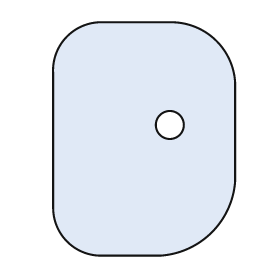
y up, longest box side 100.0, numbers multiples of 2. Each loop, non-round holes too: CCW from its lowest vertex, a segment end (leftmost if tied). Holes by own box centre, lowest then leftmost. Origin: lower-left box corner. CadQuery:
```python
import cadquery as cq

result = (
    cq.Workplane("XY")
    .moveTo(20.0, 0.0)
    .lineTo(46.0, 0.0)
    .threePointArc((68.0, 10.0), (78.0, 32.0))
    .lineTo(78.0, 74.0)
    .threePointArc((70.0, 92.0), (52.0, 100.0))
    .lineTo(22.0, 100.0)
    .threePointArc((6.0, 94.0), (0.0, 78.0))
    .lineTo(0.0, 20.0)
    .threePointArc((6.0, 6.0), (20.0, 0.0))
    .close()
    .moveTo(50.0, 56.0)
    .circle(6.0)
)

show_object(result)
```